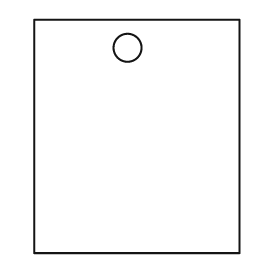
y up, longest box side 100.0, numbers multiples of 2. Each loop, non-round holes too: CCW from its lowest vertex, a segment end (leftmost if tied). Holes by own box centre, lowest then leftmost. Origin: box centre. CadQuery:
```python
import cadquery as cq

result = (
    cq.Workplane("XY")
    .moveTo(-44.0, -50.0)
    .lineTo(44.0, -50.0)
    .lineTo(44.0, 50.0)
    .lineTo(-44.0, 50.0)
    .close()
    .moveTo(-4.0, 38.0)
    .circle(6.0)
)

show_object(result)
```